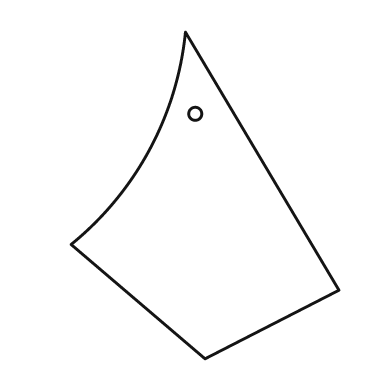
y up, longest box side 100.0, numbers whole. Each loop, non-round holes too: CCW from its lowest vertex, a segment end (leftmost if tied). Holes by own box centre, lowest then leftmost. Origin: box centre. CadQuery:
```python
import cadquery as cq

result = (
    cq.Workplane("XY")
    .moveTo(0.0, -50.0)
    .lineTo(41.0, -29.0)
    .lineTo(-6.0, 50.0)
    .threePointArc((-17.0, 14.0), (-41.0, -15.0))
    .close()
    .moveTo(-3.0, 25.0)
    .circle(2.0)
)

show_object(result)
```